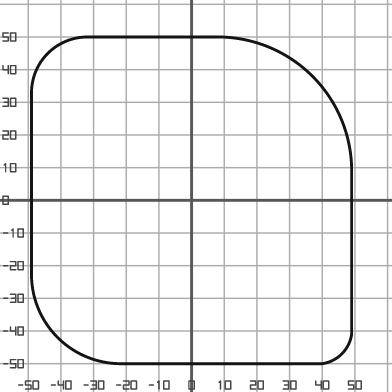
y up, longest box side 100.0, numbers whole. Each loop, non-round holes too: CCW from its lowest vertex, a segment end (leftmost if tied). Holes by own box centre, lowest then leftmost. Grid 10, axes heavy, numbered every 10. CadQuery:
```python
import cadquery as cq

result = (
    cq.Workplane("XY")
    .moveTo(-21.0, -50.0)
    .lineTo(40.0, -50.0)
    .threePointArc((46.0, -47.0), (49.0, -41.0))
    .lineTo(49.0, 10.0)
    .threePointArc((37.0, 38.0), (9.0, 50.0))
    .lineTo(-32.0, 50.0)
    .threePointArc((-44.0, 45.0), (-49.0, 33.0))
    .lineTo(-49.0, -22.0)
    .threePointArc((-41.0, -42.0), (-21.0, -50.0))
    .close()
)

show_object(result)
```